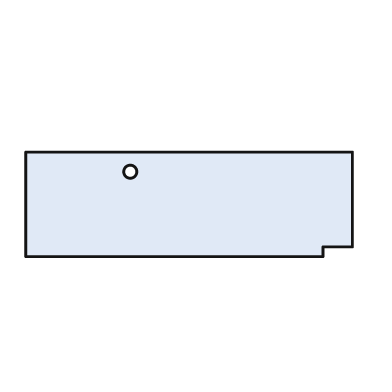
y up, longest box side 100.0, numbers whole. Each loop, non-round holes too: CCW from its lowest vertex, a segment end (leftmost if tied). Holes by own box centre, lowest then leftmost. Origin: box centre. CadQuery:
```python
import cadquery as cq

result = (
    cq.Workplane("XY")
    .moveTo(-50.0, -16.0)
    .lineTo(41.0, -16.0)
    .lineTo(41.0, -13.0)
    .lineTo(50.0, -13.0)
    .lineTo(50.0, 16.0)
    .lineTo(-50.0, 16.0)
    .close()
    .moveTo(-18.0, 10.0)
    .circle(2.0)
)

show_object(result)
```